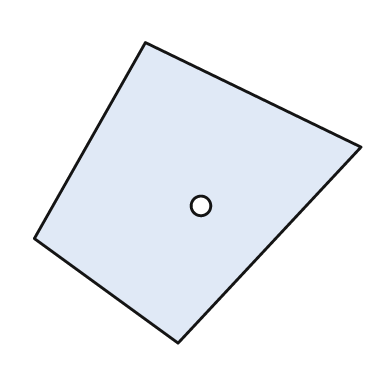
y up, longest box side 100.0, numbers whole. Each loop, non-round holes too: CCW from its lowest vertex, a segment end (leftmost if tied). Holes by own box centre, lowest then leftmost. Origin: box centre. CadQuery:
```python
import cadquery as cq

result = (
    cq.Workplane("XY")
    .moveTo(-6.0, -46.0)
    .lineTo(50.0, 14.0)
    .lineTo(-16.0, 46.0)
    .lineTo(-50.0, -14.0)
    .close()
    .moveTo(1.0, -4.0)
    .circle(3.0)
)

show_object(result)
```